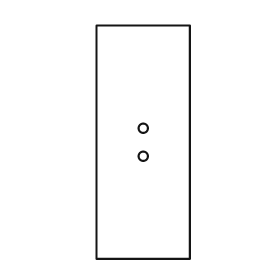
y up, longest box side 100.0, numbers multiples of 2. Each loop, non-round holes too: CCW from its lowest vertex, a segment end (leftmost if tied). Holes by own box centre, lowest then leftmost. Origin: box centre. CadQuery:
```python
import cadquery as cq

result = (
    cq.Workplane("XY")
    .moveTo(-20.0, -50.0)
    .lineTo(20.0, -50.0)
    .lineTo(20.0, 50.0)
    .lineTo(-20.0, 50.0)
    .close()
    .moveTo(0.0, -6.0)
    .circle(2.0)
    .moveTo(0.0, 6.0)
    .circle(2.0)
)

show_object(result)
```